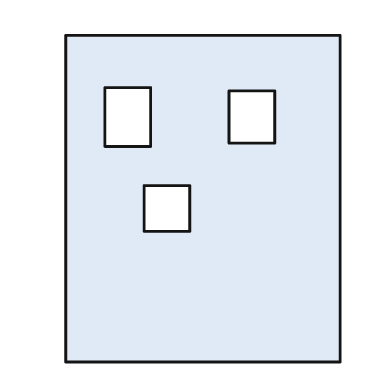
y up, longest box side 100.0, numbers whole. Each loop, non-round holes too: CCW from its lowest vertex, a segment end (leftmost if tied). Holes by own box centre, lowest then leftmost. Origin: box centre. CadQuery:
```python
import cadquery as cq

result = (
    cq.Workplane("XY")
    .moveTo(-42.0, -50.0)
    .lineTo(42.0, -50.0)
    .lineTo(42.0, 50.0)
    .lineTo(-42.0, 50.0)
    .close()
    .moveTo(-18.0, -10.0)
    .lineTo(-4.0, -10.0)
    .lineTo(-4.0, 4.0)
    .lineTo(-18.0, 4.0)
    .close()
    .moveTo(-30.0, 16.0)
    .lineTo(-16.0, 16.0)
    .lineTo(-16.0, 34.0)
    .lineTo(-30.0, 34.0)
    .close()
    .moveTo(8.0, 17.0)
    .lineTo(22.0, 17.0)
    .lineTo(22.0, 33.0)
    .lineTo(8.0, 33.0)
    .close()
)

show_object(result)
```